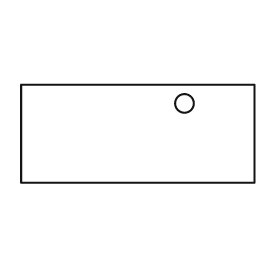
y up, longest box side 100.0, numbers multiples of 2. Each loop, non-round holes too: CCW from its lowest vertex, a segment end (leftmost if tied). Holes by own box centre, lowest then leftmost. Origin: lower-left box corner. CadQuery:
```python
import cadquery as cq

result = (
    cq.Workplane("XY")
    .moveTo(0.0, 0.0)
    .lineTo(100.0, 0.0)
    .lineTo(100.0, 42.0)
    .lineTo(0.0, 42.0)
    .close()
    .moveTo(70.0, 34.0)
    .circle(4.0)
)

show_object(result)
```